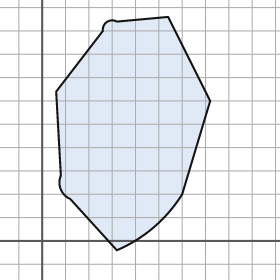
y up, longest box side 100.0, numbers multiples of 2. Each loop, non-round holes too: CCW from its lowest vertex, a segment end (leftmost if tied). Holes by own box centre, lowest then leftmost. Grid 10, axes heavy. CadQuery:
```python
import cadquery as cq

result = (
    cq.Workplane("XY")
    .moveTo(32.0, -4.0)
    .threePointArc((48.0, 6.0), (60.0, 20.0))
    .lineTo(72.0, 60.0)
    .lineTo(54.0, 96.0)
    .lineTo(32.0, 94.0)
    .threePointArc((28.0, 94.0), (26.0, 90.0))
    .lineTo(6.0, 64.0)
    .lineTo(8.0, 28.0)
    .threePointArc((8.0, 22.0), (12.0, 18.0))
    .close()
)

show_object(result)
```